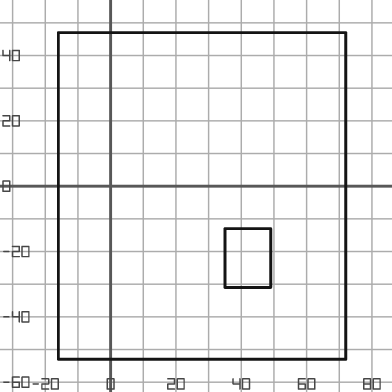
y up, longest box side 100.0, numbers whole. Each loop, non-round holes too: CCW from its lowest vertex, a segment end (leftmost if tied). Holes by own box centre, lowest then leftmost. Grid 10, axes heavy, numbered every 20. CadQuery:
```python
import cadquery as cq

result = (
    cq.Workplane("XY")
    .moveTo(-16.0, -53.0)
    .lineTo(72.0, -53.0)
    .lineTo(72.0, 47.0)
    .lineTo(-16.0, 47.0)
    .close()
    .moveTo(35.0, -31.0)
    .lineTo(49.0, -31.0)
    .lineTo(49.0, -13.0)
    .lineTo(35.0, -13.0)
    .close()
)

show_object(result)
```